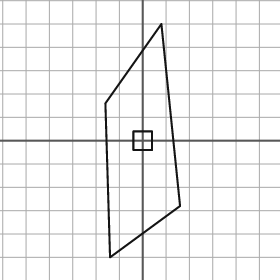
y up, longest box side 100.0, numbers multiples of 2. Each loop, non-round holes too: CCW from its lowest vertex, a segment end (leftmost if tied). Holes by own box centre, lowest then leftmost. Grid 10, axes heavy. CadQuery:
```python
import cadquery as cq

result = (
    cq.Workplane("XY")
    .moveTo(-14.0, -50.0)
    .lineTo(16.0, -28.0)
    .lineTo(8.0, 50.0)
    .lineTo(-16.0, 16.0)
    .close()
    .moveTo(-4.0, -4.0)
    .lineTo(4.0, -4.0)
    .lineTo(4.0, 4.0)
    .lineTo(-4.0, 4.0)
    .close()
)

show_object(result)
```